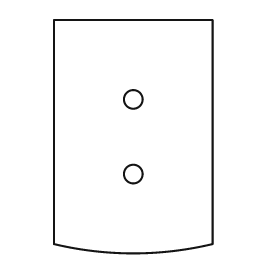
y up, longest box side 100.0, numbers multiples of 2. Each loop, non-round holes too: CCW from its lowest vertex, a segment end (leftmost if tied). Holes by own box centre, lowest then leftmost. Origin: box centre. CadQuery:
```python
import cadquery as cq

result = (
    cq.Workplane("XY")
    .moveTo(-34.0, -46.0)
    .threePointArc((0.0, -50.0), (34.0, -46.0))
    .lineTo(34.0, 50.0)
    .lineTo(-34.0, 50.0)
    .close()
    .moveTo(0.0, -16.0)
    .circle(4.0)
    .moveTo(0.0, 16.0)
    .circle(4.0)
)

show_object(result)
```